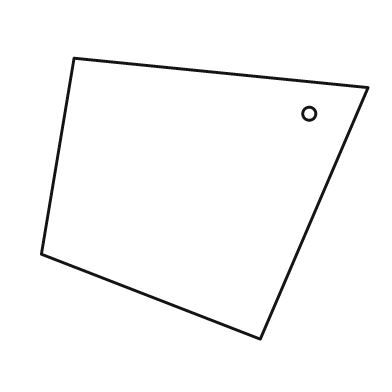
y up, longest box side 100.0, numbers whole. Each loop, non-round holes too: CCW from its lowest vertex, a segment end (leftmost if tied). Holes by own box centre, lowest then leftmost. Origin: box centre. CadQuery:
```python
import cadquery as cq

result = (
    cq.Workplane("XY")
    .moveTo(17.0, -43.0)
    .lineTo(50.0, 34.0)
    .lineTo(-40.0, 43.0)
    .lineTo(-50.0, -17.0)
    .close()
    .moveTo(32.0, 26.0)
    .circle(2.0)
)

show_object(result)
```